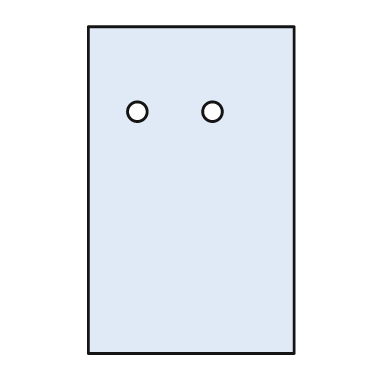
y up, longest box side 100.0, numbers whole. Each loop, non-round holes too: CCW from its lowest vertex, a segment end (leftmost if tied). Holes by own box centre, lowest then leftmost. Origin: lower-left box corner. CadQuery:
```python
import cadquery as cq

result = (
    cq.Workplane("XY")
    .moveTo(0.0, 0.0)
    .lineTo(63.0, 0.0)
    .lineTo(63.0, 100.0)
    .lineTo(0.0, 100.0)
    .close()
    .moveTo(15.0, 74.0)
    .circle(3.0)
    .moveTo(38.0, 74.0)
    .circle(3.0)
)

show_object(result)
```